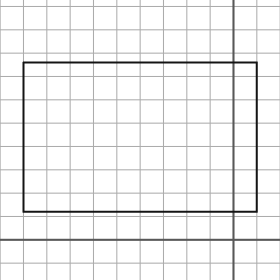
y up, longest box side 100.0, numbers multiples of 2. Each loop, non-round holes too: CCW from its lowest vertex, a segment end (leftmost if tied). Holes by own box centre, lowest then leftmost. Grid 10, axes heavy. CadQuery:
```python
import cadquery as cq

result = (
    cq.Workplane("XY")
    .moveTo(-90.0, 12.0)
    .lineTo(10.0, 12.0)
    .lineTo(10.0, 76.0)
    .lineTo(-90.0, 76.0)
    .close()
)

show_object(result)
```